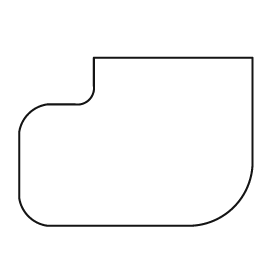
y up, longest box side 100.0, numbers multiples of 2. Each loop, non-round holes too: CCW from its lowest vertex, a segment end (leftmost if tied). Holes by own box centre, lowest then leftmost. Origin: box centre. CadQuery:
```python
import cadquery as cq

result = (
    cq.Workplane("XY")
    .moveTo(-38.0, -36.0)
    .lineTo(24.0, -36.0)
    .threePointArc((42.0, -28.0), (50.0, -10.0))
    .lineTo(50.0, 36.0)
    .lineTo(-18.0, 36.0)
    .lineTo(-18.0, 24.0)
    .threePointArc((-20.0, 18.0), (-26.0, 16.0))
    .lineTo(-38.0, 16.0)
    .threePointArc((-46.0, 12.0), (-50.0, 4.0))
    .lineTo(-50.0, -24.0)
    .threePointArc((-46.0, -32.0), (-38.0, -36.0))
    .close()
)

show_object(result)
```